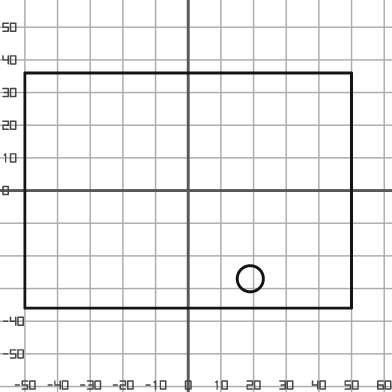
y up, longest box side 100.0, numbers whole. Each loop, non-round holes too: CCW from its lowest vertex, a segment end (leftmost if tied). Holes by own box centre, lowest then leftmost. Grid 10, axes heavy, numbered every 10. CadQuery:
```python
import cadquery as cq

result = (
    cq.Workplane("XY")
    .moveTo(-50.0, -36.0)
    .lineTo(50.0, -36.0)
    .lineTo(50.0, 36.0)
    .lineTo(-50.0, 36.0)
    .close()
    .moveTo(19.0, -27.0)
    .circle(4.0)
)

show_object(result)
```